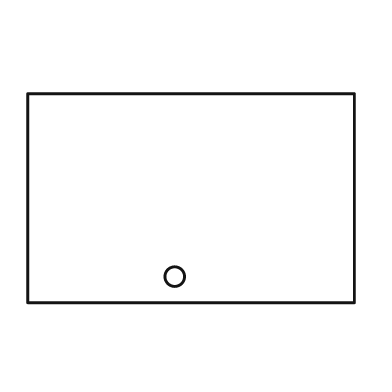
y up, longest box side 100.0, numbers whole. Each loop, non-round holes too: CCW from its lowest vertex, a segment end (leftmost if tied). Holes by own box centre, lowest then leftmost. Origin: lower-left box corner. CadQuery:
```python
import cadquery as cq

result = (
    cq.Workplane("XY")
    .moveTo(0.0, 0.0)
    .lineTo(100.0, 0.0)
    .lineTo(100.0, 64.0)
    .lineTo(0.0, 64.0)
    .close()
    .moveTo(45.0, 8.0)
    .circle(3.0)
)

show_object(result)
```